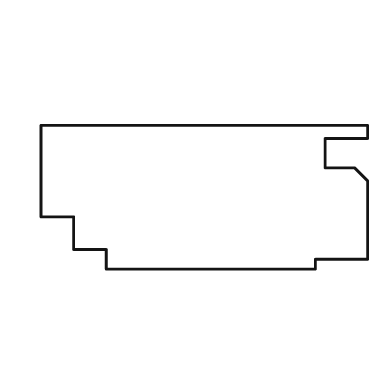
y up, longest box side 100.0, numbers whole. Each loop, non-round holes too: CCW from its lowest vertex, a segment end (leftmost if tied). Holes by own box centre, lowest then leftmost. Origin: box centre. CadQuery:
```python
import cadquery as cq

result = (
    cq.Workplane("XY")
    .moveTo(-30.0, -22.0)
    .lineTo(34.0, -22.0)
    .lineTo(34.0, -19.0)
    .lineTo(50.0, -19.0)
    .lineTo(50.0, 5.0)
    .lineTo(46.0, 9.0)
    .lineTo(37.0, 9.0)
    .lineTo(37.0, 18.0)
    .lineTo(50.0, 18.0)
    .lineTo(50.0, 22.0)
    .lineTo(-50.0, 22.0)
    .lineTo(-50.0, -6.0)
    .lineTo(-40.0, -6.0)
    .lineTo(-40.0, -16.0)
    .lineTo(-30.0, -16.0)
    .close()
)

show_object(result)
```